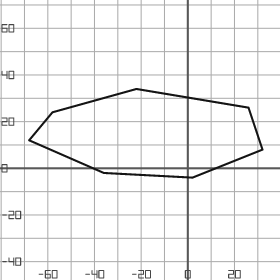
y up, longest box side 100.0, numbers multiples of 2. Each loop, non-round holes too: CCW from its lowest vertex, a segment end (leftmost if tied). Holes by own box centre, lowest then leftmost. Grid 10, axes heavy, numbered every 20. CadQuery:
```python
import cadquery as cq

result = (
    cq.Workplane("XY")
    .moveTo(2.0, -4.0)
    .lineTo(32.0, 8.0)
    .lineTo(26.0, 26.0)
    .lineTo(-22.0, 34.0)
    .lineTo(-58.0, 24.0)
    .lineTo(-68.0, 12.0)
    .lineTo(-36.0, -2.0)
    .close()
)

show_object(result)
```